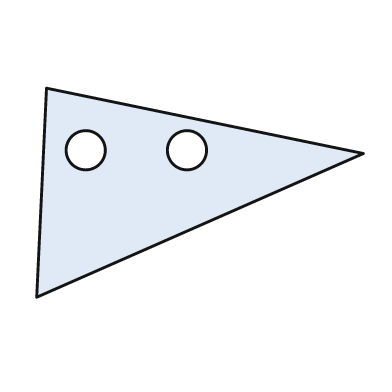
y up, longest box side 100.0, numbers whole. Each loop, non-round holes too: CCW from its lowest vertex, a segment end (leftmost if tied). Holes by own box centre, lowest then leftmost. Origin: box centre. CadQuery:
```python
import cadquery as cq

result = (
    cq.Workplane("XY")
    .moveTo(-50.0, -32.0)
    .lineTo(50.0, 12.0)
    .lineTo(-47.0, 32.0)
    .close()
    .moveTo(-35.0, 13.0)
    .circle(6.0)
    .moveTo(-4.0, 13.0)
    .circle(6.0)
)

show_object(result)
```